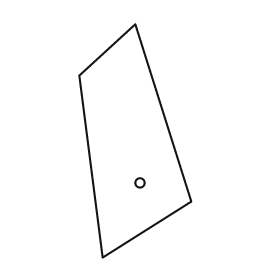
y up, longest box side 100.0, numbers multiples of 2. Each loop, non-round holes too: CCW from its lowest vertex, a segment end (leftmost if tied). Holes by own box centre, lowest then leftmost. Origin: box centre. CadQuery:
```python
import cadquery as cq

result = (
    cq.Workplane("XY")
    .moveTo(-14.0, -50.0)
    .lineTo(24.0, -26.0)
    .lineTo(0.0, 50.0)
    .lineTo(-24.0, 28.0)
    .close()
    .moveTo(2.0, -18.0)
    .circle(2.0)
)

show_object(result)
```